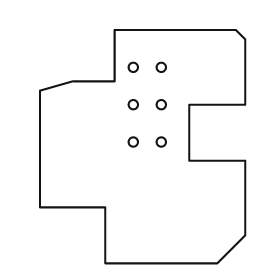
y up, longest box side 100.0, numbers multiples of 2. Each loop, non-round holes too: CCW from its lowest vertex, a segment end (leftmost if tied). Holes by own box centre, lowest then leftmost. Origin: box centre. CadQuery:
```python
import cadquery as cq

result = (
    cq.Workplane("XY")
    .moveTo(-16.0, -50.0)
    .lineTo(32.0, -50.0)
    .lineTo(44.0, -38.0)
    .lineTo(44.0, -6.0)
    .lineTo(20.0, -6.0)
    .lineTo(20.0, 18.0)
    .lineTo(44.0, 18.0)
    .lineTo(44.0, 46.0)
    .lineTo(40.0, 50.0)
    .lineTo(-12.0, 50.0)
    .lineTo(-12.0, 28.0)
    .lineTo(-30.0, 28.0)
    .lineTo(-44.0, 24.0)
    .lineTo(-44.0, -26.0)
    .lineTo(-16.0, -26.0)
    .close()
    .moveTo(-4.0, 2.0)
    .circle(2.0)
    .moveTo(8.0, 2.0)
    .circle(2.0)
    .moveTo(-4.0, 18.0)
    .circle(2.0)
    .moveTo(8.0, 18.0)
    .circle(2.0)
    .moveTo(-4.0, 34.0)
    .circle(2.0)
    .moveTo(8.0, 34.0)
    .circle(2.0)
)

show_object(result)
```